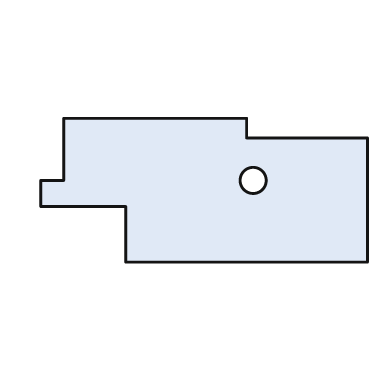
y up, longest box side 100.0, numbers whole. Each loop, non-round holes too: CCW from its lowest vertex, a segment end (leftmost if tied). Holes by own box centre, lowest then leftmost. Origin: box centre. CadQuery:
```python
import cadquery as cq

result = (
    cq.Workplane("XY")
    .moveTo(-24.0, -22.0)
    .lineTo(50.0, -22.0)
    .lineTo(50.0, 16.0)
    .lineTo(13.0, 16.0)
    .lineTo(13.0, 22.0)
    .lineTo(-43.0, 22.0)
    .lineTo(-43.0, 3.0)
    .lineTo(-50.0, 3.0)
    .lineTo(-50.0, -5.0)
    .lineTo(-24.0, -5.0)
    .close()
    .moveTo(15.0, 3.0)
    .circle(4.0)
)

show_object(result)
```